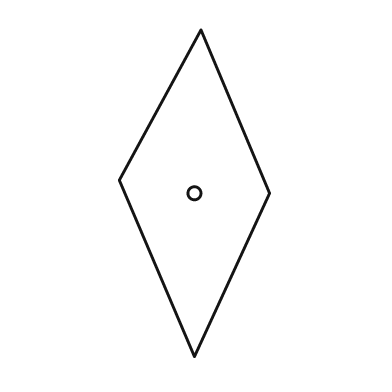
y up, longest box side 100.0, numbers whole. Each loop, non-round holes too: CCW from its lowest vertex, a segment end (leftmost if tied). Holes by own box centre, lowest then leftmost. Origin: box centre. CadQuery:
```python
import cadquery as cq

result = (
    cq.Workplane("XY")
    .moveTo(0.0, -50.0)
    .lineTo(23.0, 0.0)
    .lineTo(2.0, 50.0)
    .lineTo(-23.0, 4.0)
    .close()
    .moveTo(0.0, 0.0)
    .circle(2.0)
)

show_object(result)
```